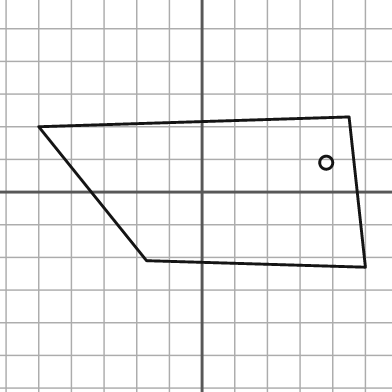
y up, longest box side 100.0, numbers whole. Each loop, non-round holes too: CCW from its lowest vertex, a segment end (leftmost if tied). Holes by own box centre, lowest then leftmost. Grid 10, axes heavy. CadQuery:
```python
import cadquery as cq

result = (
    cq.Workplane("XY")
    .moveTo(50.0, -23.0)
    .lineTo(45.0, 23.0)
    .lineTo(-50.0, 20.0)
    .lineTo(-17.0, -21.0)
    .close()
    .moveTo(38.0, 9.0)
    .circle(2.0)
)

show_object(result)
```